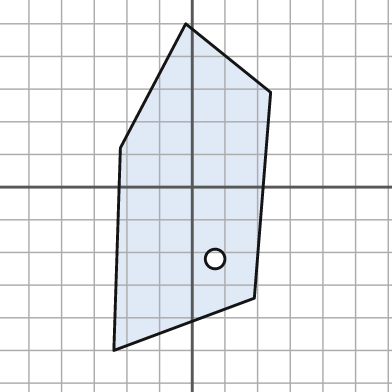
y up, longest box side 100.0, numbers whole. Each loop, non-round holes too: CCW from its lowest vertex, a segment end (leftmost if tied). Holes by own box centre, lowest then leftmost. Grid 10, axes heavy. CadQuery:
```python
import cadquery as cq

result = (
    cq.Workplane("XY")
    .moveTo(-24.0, -50.0)
    .lineTo(19.0, -34.0)
    .lineTo(24.0, 29.0)
    .lineTo(-2.0, 50.0)
    .lineTo(-22.0, 12.0)
    .close()
    .moveTo(7.0, -22.0)
    .circle(3.0)
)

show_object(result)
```